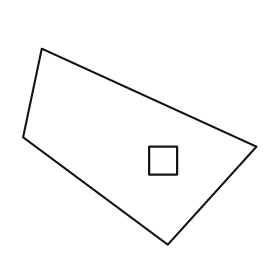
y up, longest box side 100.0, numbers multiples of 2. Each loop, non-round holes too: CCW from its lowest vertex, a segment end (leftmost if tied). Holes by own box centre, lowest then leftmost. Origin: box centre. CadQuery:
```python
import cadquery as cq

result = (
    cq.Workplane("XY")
    .moveTo(12.0, -42.0)
    .lineTo(50.0, 0.0)
    .lineTo(-42.0, 42.0)
    .lineTo(-50.0, 4.0)
    .close()
    .moveTo(4.0, -12.0)
    .lineTo(16.0, -12.0)
    .lineTo(16.0, 0.0)
    .lineTo(4.0, 0.0)
    .close()
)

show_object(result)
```